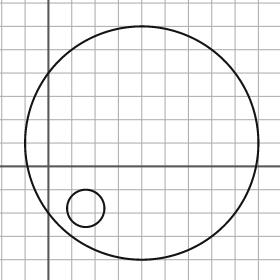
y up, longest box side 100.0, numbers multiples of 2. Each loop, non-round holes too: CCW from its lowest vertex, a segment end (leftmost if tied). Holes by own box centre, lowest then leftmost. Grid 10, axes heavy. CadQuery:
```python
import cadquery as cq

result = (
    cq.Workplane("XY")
    .moveTo(40.0, 10.0)
    .circle(50.0)
    .moveTo(16.0, -18.0)
    .circle(8.0)
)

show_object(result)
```